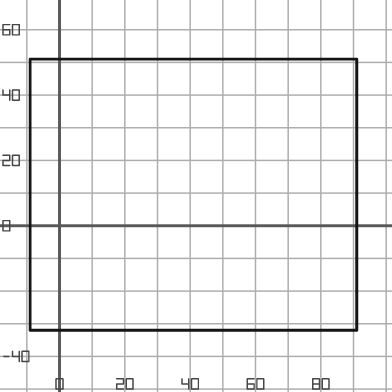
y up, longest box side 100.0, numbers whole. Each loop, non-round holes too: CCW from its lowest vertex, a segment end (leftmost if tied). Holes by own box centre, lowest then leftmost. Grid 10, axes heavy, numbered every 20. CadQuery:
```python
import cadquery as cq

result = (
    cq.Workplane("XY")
    .moveTo(-9.0, -32.0)
    .lineTo(91.0, -32.0)
    .lineTo(91.0, 51.0)
    .lineTo(-9.0, 51.0)
    .close()
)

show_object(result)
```